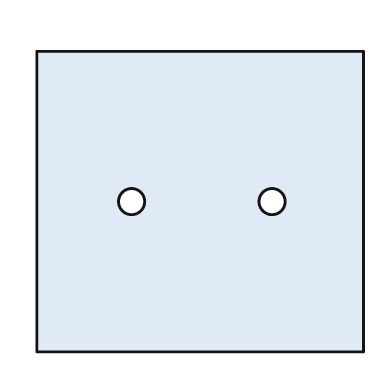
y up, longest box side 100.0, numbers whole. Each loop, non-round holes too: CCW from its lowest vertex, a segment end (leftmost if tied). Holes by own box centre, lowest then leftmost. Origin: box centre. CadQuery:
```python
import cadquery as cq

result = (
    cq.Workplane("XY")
    .moveTo(-50.0, -46.0)
    .lineTo(50.0, -46.0)
    .lineTo(50.0, 46.0)
    .lineTo(-50.0, 46.0)
    .close()
    .moveTo(-21.0, 0.0)
    .circle(4.0)
    .moveTo(22.0, 0.0)
    .circle(4.0)
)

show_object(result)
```